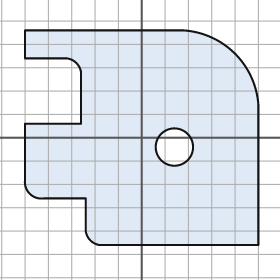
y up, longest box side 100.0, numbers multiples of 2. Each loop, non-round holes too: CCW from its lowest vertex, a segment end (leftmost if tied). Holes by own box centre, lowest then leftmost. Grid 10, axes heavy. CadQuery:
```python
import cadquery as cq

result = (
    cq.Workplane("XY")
    .moveTo(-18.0, -46.0)
    .lineTo(50.0, -46.0)
    .lineTo(50.0, 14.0)
    .threePointArc((40.0, 36.0), (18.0, 46.0))
    .lineTo(-50.0, 46.0)
    .lineTo(-50.0, 34.0)
    .lineTo(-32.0, 34.0)
    .threePointArc((-28.0, 32.0), (-26.0, 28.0))
    .lineTo(-26.0, 6.0)
    .lineTo(-50.0, 6.0)
    .lineTo(-50.0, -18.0)
    .threePointArc((-48.0, -24.0), (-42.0, -26.0))
    .lineTo(-24.0, -26.0)
    .lineTo(-24.0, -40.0)
    .threePointArc((-22.0, -44.0), (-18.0, -46.0))
    .close()
    .moveTo(14.0, -4.0)
    .circle(8.0)
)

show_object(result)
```